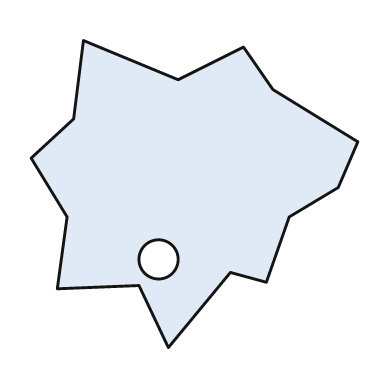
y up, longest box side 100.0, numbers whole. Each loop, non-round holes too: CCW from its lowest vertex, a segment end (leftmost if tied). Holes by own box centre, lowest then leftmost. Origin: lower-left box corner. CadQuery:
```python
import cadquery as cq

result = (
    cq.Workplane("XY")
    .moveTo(42.0, 0.0)
    .lineTo(61.0, 23.0)
    .lineTo(72.0, 20.0)
    .lineTo(79.0, 40.0)
    .lineTo(94.0, 49.0)
    .lineTo(100.0, 63.0)
    .lineTo(74.0, 79.0)
    .lineTo(65.0, 92.0)
    .lineTo(45.0, 82.0)
    .lineTo(16.0, 94.0)
    .lineTo(13.0, 70.0)
    .lineTo(0.0, 58.0)
    .lineTo(11.0, 40.0)
    .lineTo(8.0, 18.0)
    .lineTo(33.0, 19.0)
    .close()
    .moveTo(39.0, 27.0)
    .circle(6.0)
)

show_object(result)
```